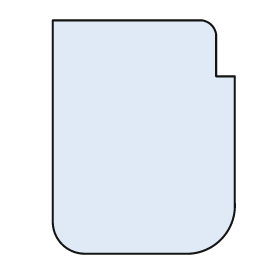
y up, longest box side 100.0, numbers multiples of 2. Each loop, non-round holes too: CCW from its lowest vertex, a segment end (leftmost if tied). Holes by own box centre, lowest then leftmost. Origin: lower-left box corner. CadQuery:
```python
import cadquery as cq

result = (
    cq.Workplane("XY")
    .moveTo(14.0, 0.0)
    .lineTo(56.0, 0.0)
    .threePointArc((72.0, 6.0), (78.0, 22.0))
    .lineTo(78.0, 76.0)
    .lineTo(70.0, 76.0)
    .lineTo(70.0, 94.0)
    .threePointArc((68.0, 98.0), (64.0, 100.0))
    .lineTo(0.0, 100.0)
    .lineTo(0.0, 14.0)
    .threePointArc((4.0, 4.0), (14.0, 0.0))
    .close()
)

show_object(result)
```